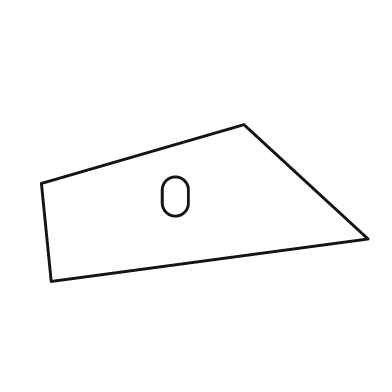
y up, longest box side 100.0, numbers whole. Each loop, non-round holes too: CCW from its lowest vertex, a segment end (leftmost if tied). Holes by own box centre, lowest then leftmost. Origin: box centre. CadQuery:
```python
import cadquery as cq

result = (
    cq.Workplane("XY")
    .moveTo(-47.0, -24.0)
    .lineTo(50.0, -11.0)
    .lineTo(12.0, 24.0)
    .lineTo(-50.0, 6.0)
    .close()
    .moveTo(-13.0, 0.0)
    .threePointArc((-9.0, -4.0), (-5.0, 0.0))
    .lineTo(-5.0, 4.0)
    .threePointArc((-9.0, 8.0), (-13.0, 4.0))
    .close()
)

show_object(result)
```